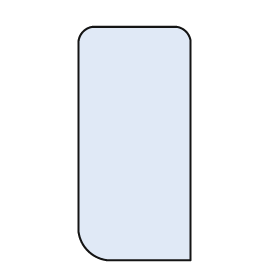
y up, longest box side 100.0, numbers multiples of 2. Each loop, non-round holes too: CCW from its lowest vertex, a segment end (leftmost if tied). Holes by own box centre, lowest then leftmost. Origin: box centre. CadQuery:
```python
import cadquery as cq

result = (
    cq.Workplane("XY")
    .moveTo(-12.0, -50.0)
    .lineTo(24.0, -50.0)
    .lineTo(24.0, 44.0)
    .threePointArc((22.0, 48.0), (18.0, 50.0))
    .lineTo(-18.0, 50.0)
    .threePointArc((-22.0, 48.0), (-24.0, 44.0))
    .lineTo(-24.0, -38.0)
    .threePointArc((-20.0, -46.0), (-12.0, -50.0))
    .close()
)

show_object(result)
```